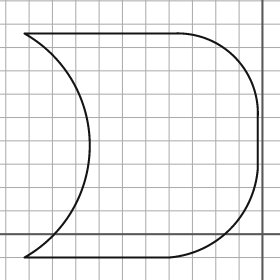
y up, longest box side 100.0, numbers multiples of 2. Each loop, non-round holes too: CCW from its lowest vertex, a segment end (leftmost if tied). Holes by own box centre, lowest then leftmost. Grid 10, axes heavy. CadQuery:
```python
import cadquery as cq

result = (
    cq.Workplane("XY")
    .moveTo(-102.0, -10.0)
    .lineTo(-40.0, -10.0)
    .threePointArc((-14.0, 2.0), (-2.0, 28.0))
    .lineTo(-2.0, 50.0)
    .threePointArc((-12.0, 76.0), (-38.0, 86.0))
    .lineTo(-102.0, 86.0)
    .threePointArc((-74.0, 38.0), (-102.0, -10.0))
    .close()
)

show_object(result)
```